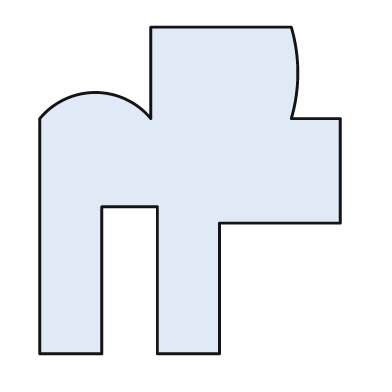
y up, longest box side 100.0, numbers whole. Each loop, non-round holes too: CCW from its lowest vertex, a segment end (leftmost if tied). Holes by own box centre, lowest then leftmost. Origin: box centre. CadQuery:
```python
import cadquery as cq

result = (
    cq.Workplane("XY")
    .moveTo(-46.0, -50.0)
    .lineTo(-27.0, -50.0)
    .lineTo(-27.0, -5.0)
    .lineTo(-10.0, -5.0)
    .lineTo(-10.0, -50.0)
    .lineTo(9.0, -50.0)
    .lineTo(9.0, -10.0)
    .lineTo(46.0, -10.0)
    .lineTo(46.0, 22.0)
    .lineTo(31.0, 22.0)
    .threePointArc((33.0, 36.0), (31.0, 50.0))
    .lineTo(-12.0, 50.0)
    .lineTo(-12.0, 22.0)
    .threePointArc((-29.0, 30.0), (-46.0, 22.0))
    .close()
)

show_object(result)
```